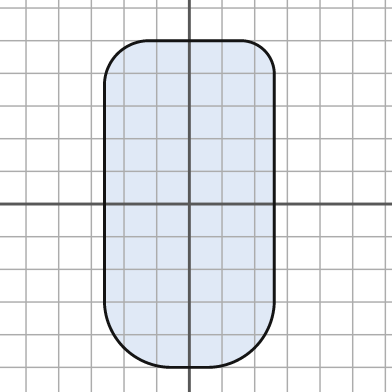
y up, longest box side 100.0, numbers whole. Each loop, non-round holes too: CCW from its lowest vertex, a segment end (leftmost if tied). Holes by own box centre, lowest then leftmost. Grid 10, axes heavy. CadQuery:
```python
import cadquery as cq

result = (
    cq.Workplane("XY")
    .moveTo(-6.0, -50.0)
    .lineTo(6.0, -50.0)
    .threePointArc((20.0, -44.0), (26.0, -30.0))
    .lineTo(26.0, 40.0)
    .threePointArc((23.0, 47.0), (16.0, 50.0))
    .lineTo(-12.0, 50.0)
    .threePointArc((-22.0, 46.0), (-26.0, 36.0))
    .lineTo(-26.0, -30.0)
    .threePointArc((-20.0, -44.0), (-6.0, -50.0))
    .close()
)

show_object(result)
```